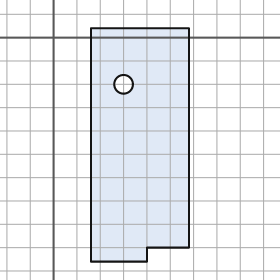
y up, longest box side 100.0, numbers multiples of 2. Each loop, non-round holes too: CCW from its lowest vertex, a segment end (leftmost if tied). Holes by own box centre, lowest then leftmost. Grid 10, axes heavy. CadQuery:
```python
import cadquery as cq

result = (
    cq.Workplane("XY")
    .moveTo(16.0, -96.0)
    .lineTo(40.0, -96.0)
    .lineTo(40.0, -90.0)
    .lineTo(58.0, -90.0)
    .lineTo(58.0, 4.0)
    .lineTo(16.0, 4.0)
    .close()
    .moveTo(30.0, -20.0)
    .circle(4.0)
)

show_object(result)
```